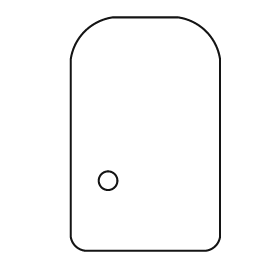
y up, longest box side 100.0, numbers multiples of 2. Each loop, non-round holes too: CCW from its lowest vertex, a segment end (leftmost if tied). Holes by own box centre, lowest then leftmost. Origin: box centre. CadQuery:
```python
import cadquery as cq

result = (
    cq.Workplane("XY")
    .moveTo(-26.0, -50.0)
    .lineTo(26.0, -50.0)
    .threePointArc((30.0, -48.0), (32.0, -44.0))
    .lineTo(32.0, 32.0)
    .threePointArc((26.0, 44.0), (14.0, 50.0))
    .lineTo(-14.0, 50.0)
    .threePointArc((-26.0, 44.0), (-32.0, 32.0))
    .lineTo(-32.0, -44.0)
    .threePointArc((-30.0, -48.0), (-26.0, -50.0))
    .close()
    .moveTo(-16.0, -20.0)
    .circle(4.0)
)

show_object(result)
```